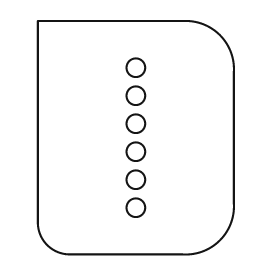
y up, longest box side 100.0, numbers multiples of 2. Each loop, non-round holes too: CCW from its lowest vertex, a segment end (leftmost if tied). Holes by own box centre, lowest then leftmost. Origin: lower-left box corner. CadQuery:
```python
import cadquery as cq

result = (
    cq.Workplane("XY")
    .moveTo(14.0, 0.0)
    .lineTo(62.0, 0.0)
    .threePointArc((78.0, 6.0), (84.0, 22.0))
    .lineTo(84.0, 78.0)
    .threePointArc((78.0, 94.0), (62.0, 100.0))
    .lineTo(0.0, 100.0)
    .lineTo(0.0, 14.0)
    .threePointArc((4.0, 4.0), (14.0, 0.0))
    .close()
    .moveTo(42.0, 20.0)
    .circle(4.0)
    .moveTo(42.0, 32.0)
    .circle(4.0)
    .moveTo(42.0, 44.0)
    .circle(4.0)
    .moveTo(42.0, 56.0)
    .circle(4.0)
    .moveTo(42.0, 68.0)
    .circle(4.0)
    .moveTo(42.0, 80.0)
    .circle(4.0)
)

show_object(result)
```